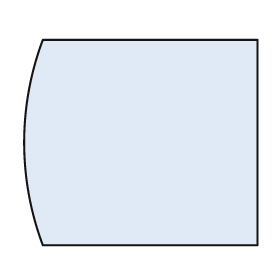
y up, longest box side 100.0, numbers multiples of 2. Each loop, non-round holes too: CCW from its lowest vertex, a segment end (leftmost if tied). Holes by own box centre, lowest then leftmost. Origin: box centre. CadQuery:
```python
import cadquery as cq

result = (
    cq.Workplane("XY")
    .moveTo(-42.0, -44.0)
    .lineTo(50.0, -44.0)
    .lineTo(50.0, 44.0)
    .lineTo(-42.0, 44.0)
    .threePointArc((-50.0, 0.0), (-42.0, -44.0))
    .close()
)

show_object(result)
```